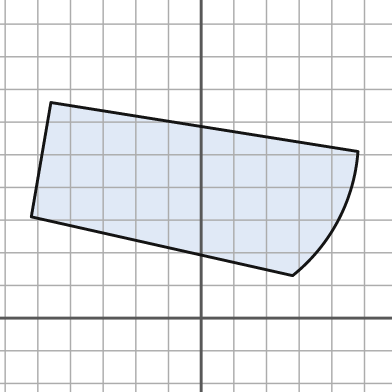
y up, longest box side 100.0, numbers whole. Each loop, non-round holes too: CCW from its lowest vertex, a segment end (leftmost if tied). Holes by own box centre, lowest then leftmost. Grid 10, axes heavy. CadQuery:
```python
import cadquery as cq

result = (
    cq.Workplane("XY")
    .moveTo(28.0, 13.0)
    .threePointArc((42.0, 30.0), (48.0, 51.0))
    .lineTo(-46.0, 66.0)
    .lineTo(-52.0, 31.0)
    .close()
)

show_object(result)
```